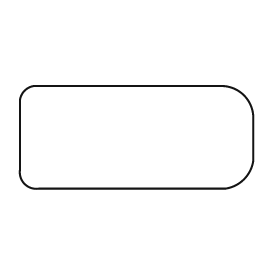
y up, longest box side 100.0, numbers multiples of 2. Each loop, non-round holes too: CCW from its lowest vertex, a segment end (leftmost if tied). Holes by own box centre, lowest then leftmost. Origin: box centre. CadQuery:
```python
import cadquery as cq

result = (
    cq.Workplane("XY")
    .moveTo(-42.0, -22.0)
    .lineTo(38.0, -22.0)
    .threePointArc((46.0, -18.0), (50.0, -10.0))
    .lineTo(50.0, 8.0)
    .threePointArc((46.0, 18.0), (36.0, 22.0))
    .lineTo(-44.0, 22.0)
    .threePointArc((-48.0, 20.0), (-50.0, 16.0))
    .lineTo(-50.0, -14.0)
    .threePointArc((-48.0, -20.0), (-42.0, -22.0))
    .close()
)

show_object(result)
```